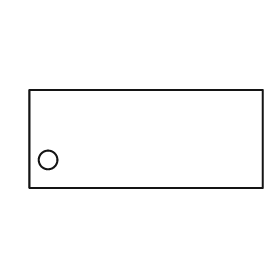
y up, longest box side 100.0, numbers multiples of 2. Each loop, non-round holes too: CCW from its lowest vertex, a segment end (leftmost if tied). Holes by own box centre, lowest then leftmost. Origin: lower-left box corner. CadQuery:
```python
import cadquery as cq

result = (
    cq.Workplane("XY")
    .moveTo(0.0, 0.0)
    .lineTo(100.0, 0.0)
    .lineTo(100.0, 42.0)
    .lineTo(0.0, 42.0)
    .close()
    .moveTo(8.0, 12.0)
    .circle(4.0)
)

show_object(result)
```